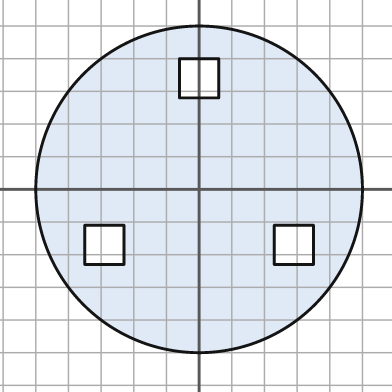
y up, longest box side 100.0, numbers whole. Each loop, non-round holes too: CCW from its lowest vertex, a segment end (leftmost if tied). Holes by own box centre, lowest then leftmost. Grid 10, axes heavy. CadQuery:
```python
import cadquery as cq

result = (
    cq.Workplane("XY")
    .moveTo(0.0, 0.0)
    .circle(50.0)
    .moveTo(-35.0, -23.0)
    .lineTo(-23.0, -23.0)
    .lineTo(-23.0, -11.0)
    .lineTo(-35.0, -11.0)
    .close()
    .moveTo(23.0, -23.0)
    .lineTo(35.0, -23.0)
    .lineTo(35.0, -11.0)
    .lineTo(23.0, -11.0)
    .close()
    .moveTo(-6.0, 28.0)
    .lineTo(6.0, 28.0)
    .lineTo(6.0, 40.0)
    .lineTo(-6.0, 40.0)
    .close()
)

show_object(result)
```